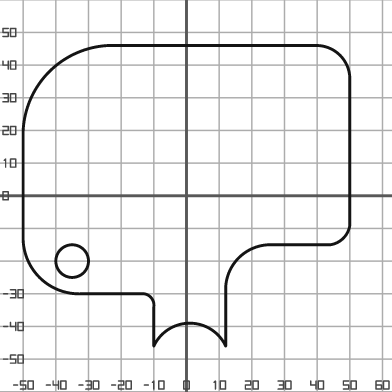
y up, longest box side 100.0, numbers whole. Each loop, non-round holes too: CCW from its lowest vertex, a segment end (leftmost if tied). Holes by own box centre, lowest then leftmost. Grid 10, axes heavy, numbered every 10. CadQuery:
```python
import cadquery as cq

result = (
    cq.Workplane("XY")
    .moveTo(-10.0, -46.0)
    .threePointArc((1.0, -39.0), (12.0, -46.0))
    .lineTo(12.0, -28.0)
    .threePointArc((16.0, -19.0), (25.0, -15.0))
    .lineTo(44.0, -15.0)
    .threePointArc((48.0, -13.0), (50.0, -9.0))
    .lineTo(50.0, 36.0)
    .threePointArc((47.0, 43.0), (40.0, 46.0))
    .lineTo(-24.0, 46.0)
    .threePointArc((-42.0, 38.0), (-50.0, 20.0))
    .lineTo(-50.0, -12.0)
    .threePointArc((-45.0, -25.0), (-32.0, -30.0))
    .lineTo(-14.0, -30.0)
    .threePointArc((-11.0, -31.0), (-10.0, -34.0))
    .close()
    .moveTo(-35.0, -20.0)
    .circle(5.0)
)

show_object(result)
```